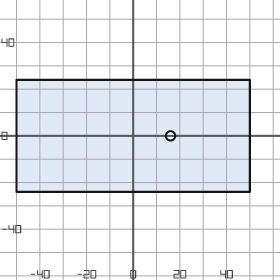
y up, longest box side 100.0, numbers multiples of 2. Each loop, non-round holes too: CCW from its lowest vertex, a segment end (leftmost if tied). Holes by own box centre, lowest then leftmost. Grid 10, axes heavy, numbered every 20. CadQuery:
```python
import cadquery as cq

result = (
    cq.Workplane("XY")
    .moveTo(-50.0, -24.0)
    .lineTo(50.0, -24.0)
    .lineTo(50.0, 24.0)
    .lineTo(-50.0, 24.0)
    .close()
    .moveTo(16.0, 0.0)
    .circle(2.0)
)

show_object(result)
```